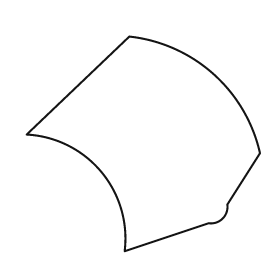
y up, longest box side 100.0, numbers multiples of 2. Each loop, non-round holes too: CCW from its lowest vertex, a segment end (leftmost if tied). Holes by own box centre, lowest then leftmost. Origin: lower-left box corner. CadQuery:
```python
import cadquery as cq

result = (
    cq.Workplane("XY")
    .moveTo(42.0, 0.0)
    .lineTo(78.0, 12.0)
    .threePointArc((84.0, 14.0), (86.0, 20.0))
    .lineTo(100.0, 42.0)
    .threePointArc((80.0, 76.0), (44.0, 92.0))
    .lineTo(0.0, 50.0)
    .threePointArc((32.0, 34.0), (42.0, 0.0))
    .close()
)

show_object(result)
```